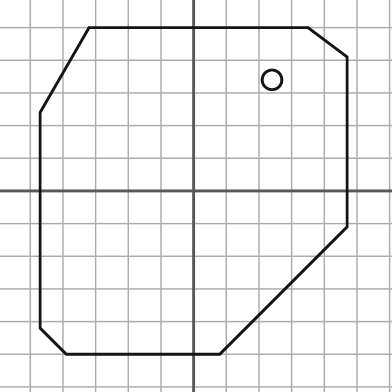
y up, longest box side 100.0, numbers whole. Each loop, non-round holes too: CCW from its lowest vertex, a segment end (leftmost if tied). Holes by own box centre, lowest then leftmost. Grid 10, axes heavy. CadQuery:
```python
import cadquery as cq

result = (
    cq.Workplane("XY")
    .moveTo(-39.0, -50.0)
    .lineTo(8.0, -50.0)
    .lineTo(47.0, -11.0)
    .lineTo(47.0, 41.0)
    .lineTo(35.0, 50.0)
    .lineTo(-32.0, 50.0)
    .lineTo(-47.0, 24.0)
    .lineTo(-47.0, -42.0)
    .close()
    .moveTo(24.0, 34.0)
    .circle(3.0)
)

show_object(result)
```